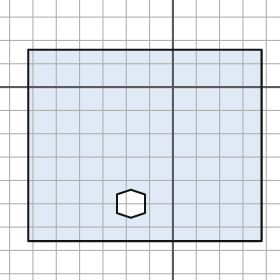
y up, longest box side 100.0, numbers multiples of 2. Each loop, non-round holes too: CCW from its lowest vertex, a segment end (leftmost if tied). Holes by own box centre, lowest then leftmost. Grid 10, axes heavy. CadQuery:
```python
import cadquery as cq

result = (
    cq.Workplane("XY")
    .moveTo(-62.0, -66.0)
    .lineTo(38.0, -66.0)
    .lineTo(38.0, 16.0)
    .lineTo(-62.0, 16.0)
    .close()
    .moveTo(-18.0, -56.0)
    .lineTo(-12.0, -54.0)
    .lineTo(-12.0, -46.0)
    .lineTo(-18.0, -44.0)
    .lineTo(-24.0, -46.0)
    .lineTo(-24.0, -54.0)
    .close()
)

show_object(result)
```